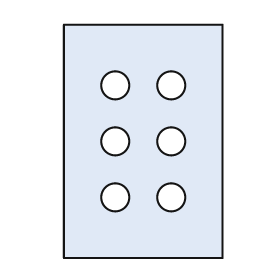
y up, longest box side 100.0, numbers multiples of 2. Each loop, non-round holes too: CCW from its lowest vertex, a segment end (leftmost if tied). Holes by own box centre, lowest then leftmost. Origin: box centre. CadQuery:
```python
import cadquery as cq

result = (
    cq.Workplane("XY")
    .moveTo(-34.0, -50.0)
    .lineTo(34.0, -50.0)
    .lineTo(34.0, 50.0)
    .lineTo(-34.0, 50.0)
    .close()
    .moveTo(-12.0, -24.0)
    .circle(6.0)
    .moveTo(12.0, -24.0)
    .circle(6.0)
    .moveTo(-12.0, 0.0)
    .circle(6.0)
    .moveTo(12.0, 0.0)
    .circle(6.0)
    .moveTo(-12.0, 24.0)
    .circle(6.0)
    .moveTo(12.0, 24.0)
    .circle(6.0)
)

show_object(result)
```